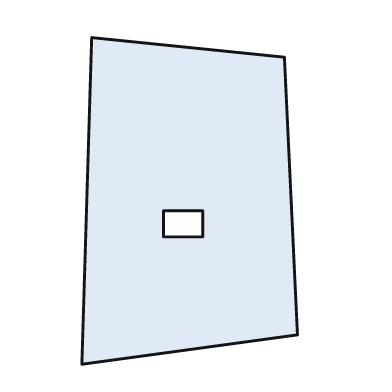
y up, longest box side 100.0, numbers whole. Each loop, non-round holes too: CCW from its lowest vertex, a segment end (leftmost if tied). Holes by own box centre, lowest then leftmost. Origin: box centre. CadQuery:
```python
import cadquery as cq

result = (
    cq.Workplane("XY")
    .moveTo(-33.0, -50.0)
    .lineTo(33.0, -41.0)
    .lineTo(29.0, 44.0)
    .lineTo(-30.0, 50.0)
    .close()
    .moveTo(-8.0, -11.0)
    .lineTo(4.0, -11.0)
    .lineTo(4.0, -3.0)
    .lineTo(-8.0, -3.0)
    .close()
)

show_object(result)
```